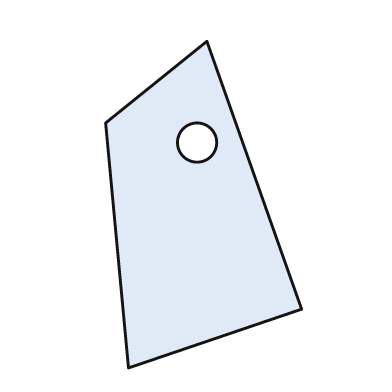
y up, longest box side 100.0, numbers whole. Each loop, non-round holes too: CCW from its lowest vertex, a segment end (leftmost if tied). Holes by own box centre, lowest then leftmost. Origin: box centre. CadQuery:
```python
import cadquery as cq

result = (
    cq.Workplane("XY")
    .moveTo(-23.0, -50.0)
    .lineTo(30.0, -32.0)
    .lineTo(1.0, 50.0)
    .lineTo(-30.0, 25.0)
    .close()
    .moveTo(-2.0, 19.0)
    .circle(6.0)
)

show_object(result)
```